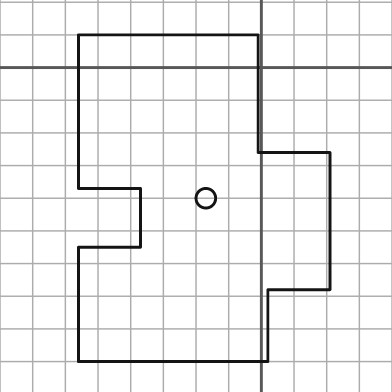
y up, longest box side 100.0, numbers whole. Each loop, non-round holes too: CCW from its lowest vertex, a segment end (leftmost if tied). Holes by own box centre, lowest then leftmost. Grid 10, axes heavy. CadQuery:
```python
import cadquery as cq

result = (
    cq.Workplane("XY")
    .moveTo(-56.0, -90.0)
    .lineTo(2.0, -90.0)
    .lineTo(2.0, -68.0)
    .lineTo(21.0, -68.0)
    .lineTo(21.0, -26.0)
    .lineTo(-1.0, -26.0)
    .lineTo(-1.0, 10.0)
    .lineTo(-56.0, 10.0)
    .lineTo(-56.0, -37.0)
    .lineTo(-37.0, -37.0)
    .lineTo(-37.0, -55.0)
    .lineTo(-56.0, -55.0)
    .close()
    .moveTo(-17.0, -40.0)
    .circle(3.0)
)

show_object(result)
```